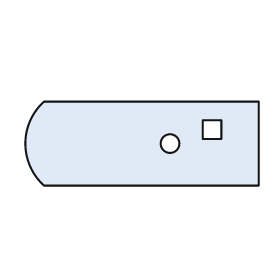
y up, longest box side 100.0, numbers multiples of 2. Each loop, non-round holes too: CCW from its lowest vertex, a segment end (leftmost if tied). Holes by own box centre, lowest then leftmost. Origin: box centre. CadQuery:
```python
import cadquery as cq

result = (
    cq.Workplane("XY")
    .moveTo(-42.0, -18.0)
    .lineTo(50.0, -18.0)
    .lineTo(50.0, 18.0)
    .lineTo(-42.0, 18.0)
    .threePointArc((-50.0, 0.0), (-42.0, -18.0))
    .close()
    .moveTo(12.0, 0.0)
    .circle(4.0)
    .moveTo(26.0, 2.0)
    .lineTo(34.0, 2.0)
    .lineTo(34.0, 10.0)
    .lineTo(26.0, 10.0)
    .close()
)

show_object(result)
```